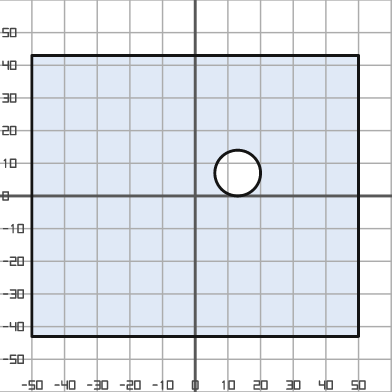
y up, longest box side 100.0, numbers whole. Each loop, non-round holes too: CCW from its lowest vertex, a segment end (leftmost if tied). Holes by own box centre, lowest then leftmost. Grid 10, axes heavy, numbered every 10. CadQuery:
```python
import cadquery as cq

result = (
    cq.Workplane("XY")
    .moveTo(-50.0, -43.0)
    .lineTo(50.0, -43.0)
    .lineTo(50.0, 43.0)
    .lineTo(-50.0, 43.0)
    .close()
    .moveTo(13.0, 7.0)
    .circle(7.0)
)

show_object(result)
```